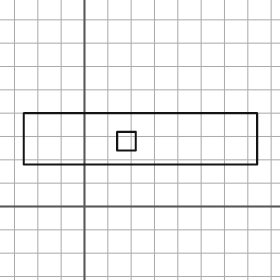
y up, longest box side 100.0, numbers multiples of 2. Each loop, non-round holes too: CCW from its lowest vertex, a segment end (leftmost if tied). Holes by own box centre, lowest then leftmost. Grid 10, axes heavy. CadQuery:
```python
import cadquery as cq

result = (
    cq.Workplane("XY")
    .moveTo(-26.0, 18.0)
    .lineTo(74.0, 18.0)
    .lineTo(74.0, 40.0)
    .lineTo(-26.0, 40.0)
    .close()
    .moveTo(14.0, 24.0)
    .lineTo(22.0, 24.0)
    .lineTo(22.0, 32.0)
    .lineTo(14.0, 32.0)
    .close()
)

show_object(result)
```